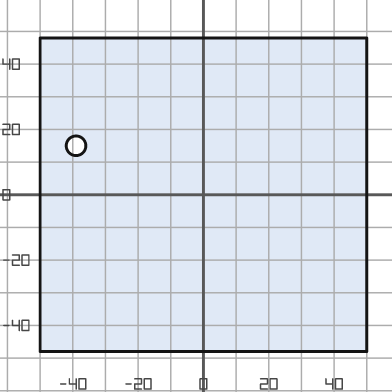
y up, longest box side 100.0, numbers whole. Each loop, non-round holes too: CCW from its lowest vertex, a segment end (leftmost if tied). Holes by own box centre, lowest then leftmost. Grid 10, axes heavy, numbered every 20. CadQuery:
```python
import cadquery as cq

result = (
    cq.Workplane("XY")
    .moveTo(-50.0, -48.0)
    .lineTo(50.0, -48.0)
    .lineTo(50.0, 48.0)
    .lineTo(-50.0, 48.0)
    .close()
    .moveTo(-39.0, 15.0)
    .circle(3.0)
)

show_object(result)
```